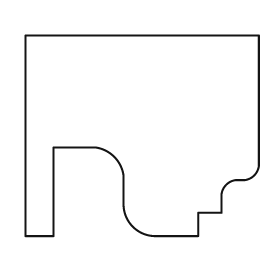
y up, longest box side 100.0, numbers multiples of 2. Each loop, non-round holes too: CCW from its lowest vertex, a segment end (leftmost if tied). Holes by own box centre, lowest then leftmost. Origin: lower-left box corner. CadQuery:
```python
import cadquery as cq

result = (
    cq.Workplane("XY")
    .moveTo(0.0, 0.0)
    .lineTo(12.0, 0.0)
    .lineTo(12.0, 38.0)
    .lineTo(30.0, 38.0)
    .threePointArc((38.0, 34.0), (42.0, 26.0))
    .lineTo(42.0, 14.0)
    .threePointArc((46.0, 4.0), (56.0, 0.0))
    .lineTo(74.0, 0.0)
    .lineTo(74.0, 10.0)
    .lineTo(84.0, 10.0)
    .lineTo(84.0, 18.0)
    .threePointArc((86.0, 22.0), (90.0, 24.0))
    .lineTo(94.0, 24.0)
    .threePointArc((98.0, 26.0), (100.0, 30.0))
    .lineTo(100.0, 86.0)
    .lineTo(0.0, 86.0)
    .close()
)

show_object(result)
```